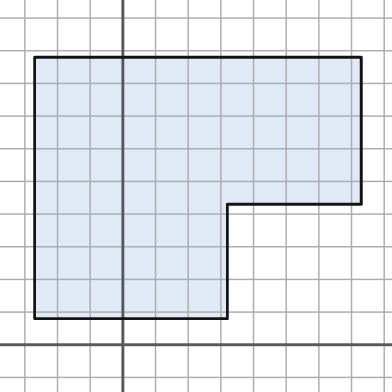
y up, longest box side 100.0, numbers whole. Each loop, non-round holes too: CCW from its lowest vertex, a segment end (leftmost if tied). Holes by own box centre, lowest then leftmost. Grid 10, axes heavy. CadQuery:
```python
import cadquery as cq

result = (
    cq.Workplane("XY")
    .moveTo(-27.0, 8.0)
    .lineTo(32.0, 8.0)
    .lineTo(32.0, 43.0)
    .lineTo(73.0, 43.0)
    .lineTo(73.0, 88.0)
    .lineTo(-27.0, 88.0)
    .close()
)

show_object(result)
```